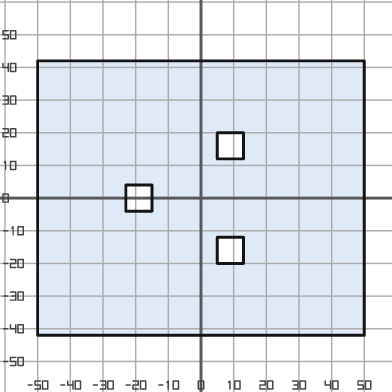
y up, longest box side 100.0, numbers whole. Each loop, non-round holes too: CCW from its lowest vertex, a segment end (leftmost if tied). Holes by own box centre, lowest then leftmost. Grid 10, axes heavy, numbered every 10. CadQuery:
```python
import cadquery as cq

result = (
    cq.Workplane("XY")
    .moveTo(-50.0, -42.0)
    .lineTo(50.0, -42.0)
    .lineTo(50.0, 42.0)
    .lineTo(-50.0, 42.0)
    .close()
    .moveTo(5.0, -20.0)
    .lineTo(13.0, -20.0)
    .lineTo(13.0, -12.0)
    .lineTo(5.0, -12.0)
    .close()
    .moveTo(-23.0, -4.0)
    .lineTo(-15.0, -4.0)
    .lineTo(-15.0, 4.0)
    .lineTo(-23.0, 4.0)
    .close()
    .moveTo(5.0, 12.0)
    .lineTo(13.0, 12.0)
    .lineTo(13.0, 20.0)
    .lineTo(5.0, 20.0)
    .close()
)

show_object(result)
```